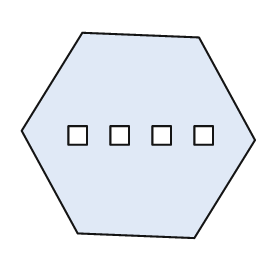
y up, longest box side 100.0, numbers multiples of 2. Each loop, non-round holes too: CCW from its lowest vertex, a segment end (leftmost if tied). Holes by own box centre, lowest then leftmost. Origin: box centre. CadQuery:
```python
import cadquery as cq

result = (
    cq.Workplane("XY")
    .moveTo(24.0, -44.0)
    .lineTo(50.0, -2.0)
    .lineTo(26.0, 42.0)
    .lineTo(-24.0, 44.0)
    .lineTo(-50.0, 2.0)
    .lineTo(-26.0, -42.0)
    .close()
    .moveTo(-30.0, -4.0)
    .lineTo(-22.0, -4.0)
    .lineTo(-22.0, 4.0)
    .lineTo(-30.0, 4.0)
    .close()
    .moveTo(-12.0, -4.0)
    .lineTo(-4.0, -4.0)
    .lineTo(-4.0, 4.0)
    .lineTo(-12.0, 4.0)
    .close()
    .moveTo(6.0, -4.0)
    .lineTo(14.0, -4.0)
    .lineTo(14.0, 4.0)
    .lineTo(6.0, 4.0)
    .close()
    .moveTo(24.0, -4.0)
    .lineTo(32.0, -4.0)
    .lineTo(32.0, 4.0)
    .lineTo(24.0, 4.0)
    .close()
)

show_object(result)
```